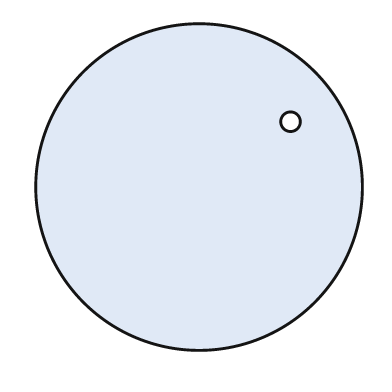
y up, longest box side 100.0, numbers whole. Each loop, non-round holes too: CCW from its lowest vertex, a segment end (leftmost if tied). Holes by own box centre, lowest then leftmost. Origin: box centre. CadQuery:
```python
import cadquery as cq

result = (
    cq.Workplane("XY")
    .moveTo(0.0, 0.0)
    .circle(50.0)
    .moveTo(28.0, 20.0)
    .circle(3.0)
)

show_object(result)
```